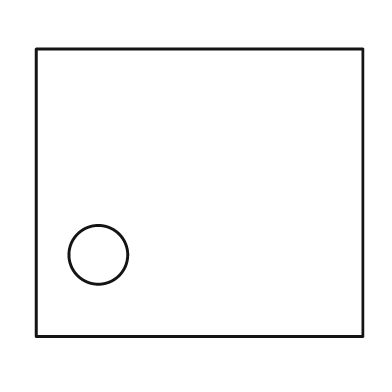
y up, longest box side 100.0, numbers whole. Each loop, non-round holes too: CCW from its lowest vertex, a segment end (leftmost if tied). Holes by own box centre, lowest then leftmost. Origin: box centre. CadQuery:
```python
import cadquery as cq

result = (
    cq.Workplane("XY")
    .moveTo(-50.0, -44.0)
    .lineTo(50.0, -44.0)
    .lineTo(50.0, 44.0)
    .lineTo(-50.0, 44.0)
    .close()
    .moveTo(-31.0, -19.0)
    .circle(9.0)
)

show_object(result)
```